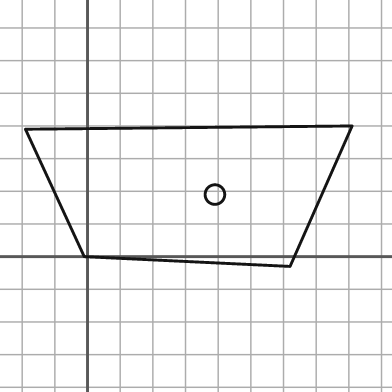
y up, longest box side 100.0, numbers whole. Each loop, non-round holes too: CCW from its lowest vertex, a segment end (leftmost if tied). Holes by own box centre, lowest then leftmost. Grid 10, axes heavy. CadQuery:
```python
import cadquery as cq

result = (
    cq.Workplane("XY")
    .moveTo(62.0, -3.0)
    .lineTo(81.0, 40.0)
    .lineTo(-19.0, 39.0)
    .lineTo(-1.0, 0.0)
    .close()
    .moveTo(39.0, 19.0)
    .circle(3.0)
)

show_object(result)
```